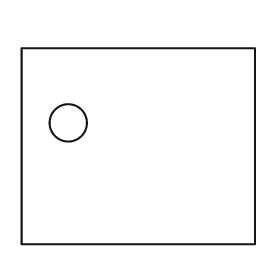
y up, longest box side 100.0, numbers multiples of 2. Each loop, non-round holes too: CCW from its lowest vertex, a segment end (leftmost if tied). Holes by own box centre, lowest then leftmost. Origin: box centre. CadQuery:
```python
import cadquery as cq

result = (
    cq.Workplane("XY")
    .moveTo(-50.0, -42.0)
    .lineTo(50.0, -42.0)
    .lineTo(50.0, 42.0)
    .lineTo(-50.0, 42.0)
    .close()
    .moveTo(-30.0, 10.0)
    .circle(8.0)
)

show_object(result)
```